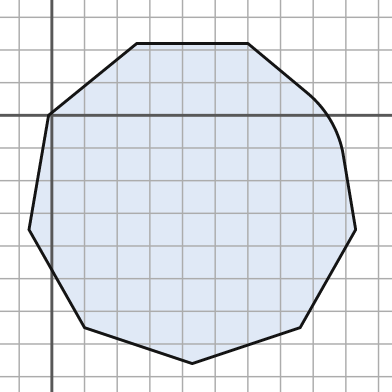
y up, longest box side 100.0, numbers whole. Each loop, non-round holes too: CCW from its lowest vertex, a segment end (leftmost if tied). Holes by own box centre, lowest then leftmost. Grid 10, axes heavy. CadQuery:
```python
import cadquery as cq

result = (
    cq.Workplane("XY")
    .moveTo(43.0, -76.0)
    .lineTo(76.0, -65.0)
    .lineTo(93.0, -35.0)
    .lineTo(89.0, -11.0)
    .threePointArc((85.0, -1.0), (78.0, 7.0))
    .lineTo(60.0, 22.0)
    .lineTo(26.0, 22.0)
    .lineTo(-1.0, 0.0)
    .lineTo(-7.0, -35.0)
    .lineTo(10.0, -65.0)
    .close()
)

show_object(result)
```